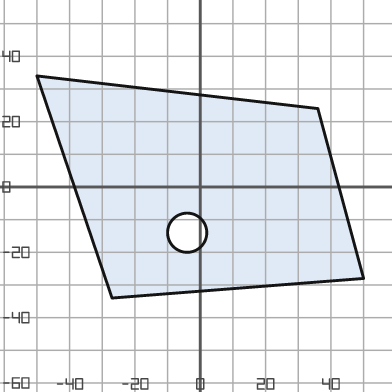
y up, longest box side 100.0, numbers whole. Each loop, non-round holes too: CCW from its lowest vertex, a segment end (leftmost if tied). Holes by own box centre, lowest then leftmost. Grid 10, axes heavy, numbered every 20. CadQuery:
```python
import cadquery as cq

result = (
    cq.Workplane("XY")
    .moveTo(-27.0, -34.0)
    .lineTo(50.0, -28.0)
    .lineTo(36.0, 24.0)
    .lineTo(-50.0, 34.0)
    .close()
    .moveTo(-4.0, -14.0)
    .circle(6.0)
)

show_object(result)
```